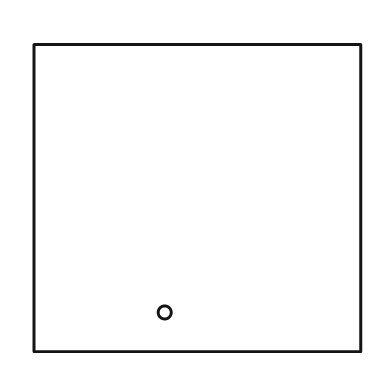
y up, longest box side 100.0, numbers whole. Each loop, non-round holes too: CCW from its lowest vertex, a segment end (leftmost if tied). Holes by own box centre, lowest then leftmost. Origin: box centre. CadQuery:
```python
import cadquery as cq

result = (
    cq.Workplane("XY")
    .moveTo(-50.0, -47.0)
    .lineTo(50.0, -47.0)
    .lineTo(50.0, 47.0)
    .lineTo(-50.0, 47.0)
    .close()
    .moveTo(-10.0, -35.0)
    .circle(2.0)
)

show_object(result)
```